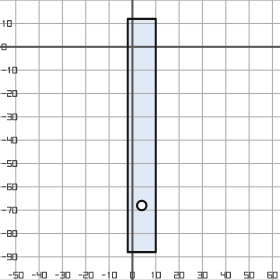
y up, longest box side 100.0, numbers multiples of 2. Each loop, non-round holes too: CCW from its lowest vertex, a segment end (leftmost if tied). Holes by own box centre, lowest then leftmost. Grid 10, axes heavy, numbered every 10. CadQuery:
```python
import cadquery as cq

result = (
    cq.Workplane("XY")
    .moveTo(-2.0, -88.0)
    .lineTo(10.0, -88.0)
    .lineTo(10.0, 12.0)
    .lineTo(-2.0, 12.0)
    .close()
    .moveTo(4.0, -68.0)
    .circle(2.0)
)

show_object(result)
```